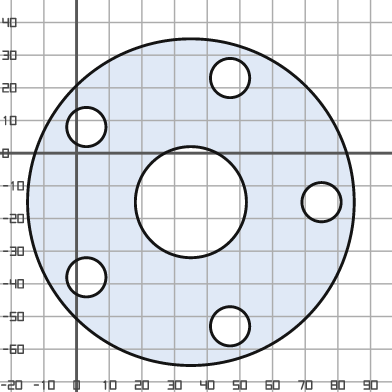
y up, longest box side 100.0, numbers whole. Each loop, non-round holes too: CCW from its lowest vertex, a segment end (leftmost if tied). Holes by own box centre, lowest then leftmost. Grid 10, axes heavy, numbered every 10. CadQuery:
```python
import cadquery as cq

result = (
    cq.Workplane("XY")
    .moveTo(35.0, -15.0)
    .circle(50.0)
    .moveTo(47.0, -53.0)
    .circle(6.0)
    .moveTo(3.0, -38.0)
    .circle(6.0)
    .moveTo(35.0, -15.0)
    .circle(17.0)
    .moveTo(75.0, -15.0)
    .circle(6.0)
    .moveTo(3.0, 8.0)
    .circle(6.0)
    .moveTo(47.0, 23.0)
    .circle(6.0)
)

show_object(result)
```